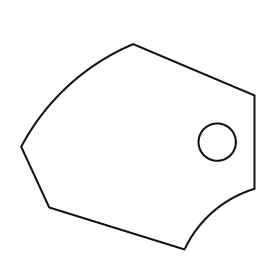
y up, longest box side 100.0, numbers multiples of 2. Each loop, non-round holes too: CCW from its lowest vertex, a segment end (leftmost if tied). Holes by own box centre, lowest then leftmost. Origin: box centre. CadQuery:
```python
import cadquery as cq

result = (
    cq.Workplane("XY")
    .moveTo(20.0, -44.0)
    .threePointArc((32.0, -28.0), (50.0, -18.0))
    .lineTo(50.0, 22.0)
    .lineTo(-2.0, 44.0)
    .threePointArc((-30.0, 26.0), (-50.0, 0.0))
    .lineTo(-38.0, -26.0)
    .close()
    .moveTo(34.0, 2.0)
    .circle(8.0)
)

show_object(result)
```